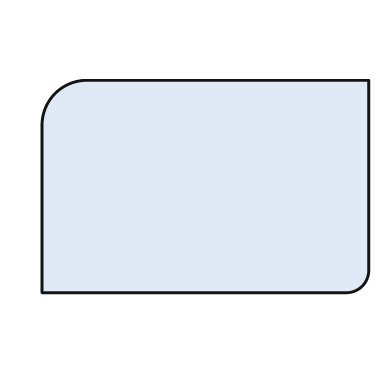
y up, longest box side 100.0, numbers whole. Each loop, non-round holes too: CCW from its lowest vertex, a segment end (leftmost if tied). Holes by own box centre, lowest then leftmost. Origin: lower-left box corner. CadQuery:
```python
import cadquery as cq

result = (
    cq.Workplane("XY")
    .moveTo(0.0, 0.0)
    .lineTo(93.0, 0.0)
    .threePointArc((98.0, 2.0), (100.0, 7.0))
    .lineTo(100.0, 65.0)
    .lineTo(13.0, 65.0)
    .threePointArc((4.0, 61.0), (0.0, 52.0))
    .close()
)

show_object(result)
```